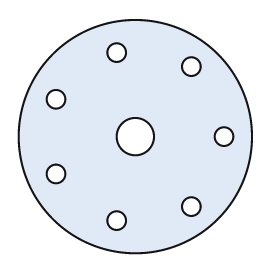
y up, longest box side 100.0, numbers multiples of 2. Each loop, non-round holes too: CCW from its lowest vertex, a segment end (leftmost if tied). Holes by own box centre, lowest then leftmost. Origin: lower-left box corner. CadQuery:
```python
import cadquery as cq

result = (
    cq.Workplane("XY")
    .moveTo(50.0, 50.0)
    .circle(50.0)
    .moveTo(42.0, 14.0)
    .circle(4.0)
    .moveTo(74.0, 20.0)
    .circle(4.0)
    .moveTo(16.0, 34.0)
    .circle(4.0)
    .moveTo(50.0, 50.0)
    .circle(8.0)
    .moveTo(88.0, 50.0)
    .circle(4.0)
    .moveTo(16.0, 66.0)
    .circle(4.0)
    .moveTo(74.0, 80.0)
    .circle(4.0)
    .moveTo(42.0, 86.0)
    .circle(4.0)
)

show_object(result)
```